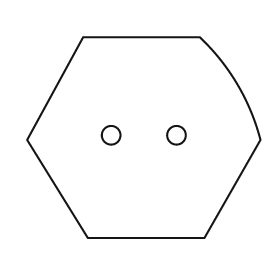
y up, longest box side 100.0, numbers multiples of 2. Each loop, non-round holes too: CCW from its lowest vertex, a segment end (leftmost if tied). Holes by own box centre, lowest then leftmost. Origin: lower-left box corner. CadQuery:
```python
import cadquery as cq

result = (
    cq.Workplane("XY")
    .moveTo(26.0, 0.0)
    .lineTo(76.0, 0.0)
    .lineTo(100.0, 42.0)
    .threePointArc((90.0, 66.0), (74.0, 86.0))
    .lineTo(24.0, 86.0)
    .lineTo(0.0, 42.0)
    .close()
    .moveTo(36.0, 44.0)
    .circle(4.0)
    .moveTo(64.0, 44.0)
    .circle(4.0)
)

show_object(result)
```